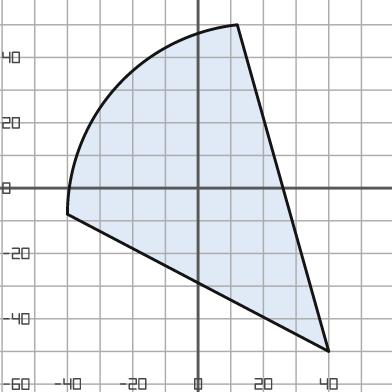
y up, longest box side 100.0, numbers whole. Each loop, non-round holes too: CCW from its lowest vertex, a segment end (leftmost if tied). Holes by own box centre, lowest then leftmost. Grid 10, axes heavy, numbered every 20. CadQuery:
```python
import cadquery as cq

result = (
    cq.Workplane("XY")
    .moveTo(40.0, -50.0)
    .lineTo(12.0, 50.0)
    .threePointArc((-25.0, 31.0), (-40.0, -8.0))
    .close()
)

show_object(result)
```